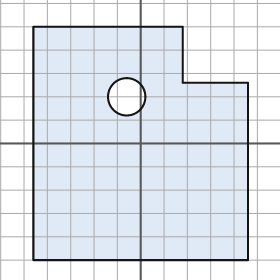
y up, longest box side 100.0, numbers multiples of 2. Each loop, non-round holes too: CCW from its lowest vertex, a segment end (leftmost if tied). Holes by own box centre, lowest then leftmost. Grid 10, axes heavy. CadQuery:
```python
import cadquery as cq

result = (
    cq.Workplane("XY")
    .moveTo(-46.0, -50.0)
    .lineTo(46.0, -50.0)
    .lineTo(46.0, 26.0)
    .lineTo(18.0, 26.0)
    .lineTo(18.0, 50.0)
    .lineTo(-46.0, 50.0)
    .close()
    .moveTo(-6.0, 20.0)
    .circle(8.0)
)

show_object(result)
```